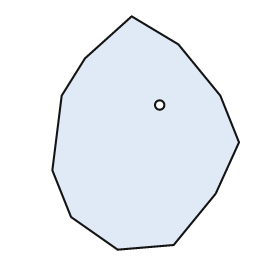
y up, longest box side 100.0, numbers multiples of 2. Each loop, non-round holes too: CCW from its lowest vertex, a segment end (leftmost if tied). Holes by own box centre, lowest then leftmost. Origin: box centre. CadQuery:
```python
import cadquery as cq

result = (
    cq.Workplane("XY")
    .moveTo(-12.0, -50.0)
    .lineTo(12.0, -48.0)
    .lineTo(30.0, -26.0)
    .lineTo(40.0, -4.0)
    .lineTo(32.0, 16.0)
    .lineTo(14.0, 38.0)
    .lineTo(-6.0, 50.0)
    .lineTo(-26.0, 32.0)
    .lineTo(-36.0, 16.0)
    .lineTo(-40.0, -16.0)
    .lineTo(-32.0, -36.0)
    .close()
    .moveTo(6.0, 12.0)
    .circle(2.0)
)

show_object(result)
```